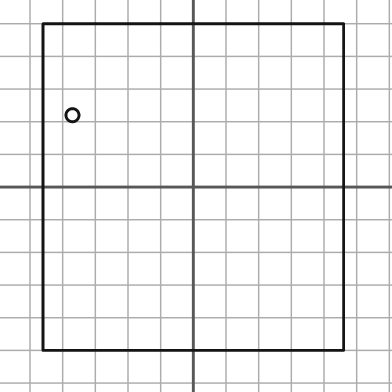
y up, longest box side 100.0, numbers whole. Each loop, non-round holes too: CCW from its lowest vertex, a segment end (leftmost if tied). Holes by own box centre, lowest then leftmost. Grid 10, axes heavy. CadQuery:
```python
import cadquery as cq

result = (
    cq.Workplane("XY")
    .moveTo(-46.0, -50.0)
    .lineTo(46.0, -50.0)
    .lineTo(46.0, 50.0)
    .lineTo(-46.0, 50.0)
    .close()
    .moveTo(-37.0, 22.0)
    .circle(2.0)
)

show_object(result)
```